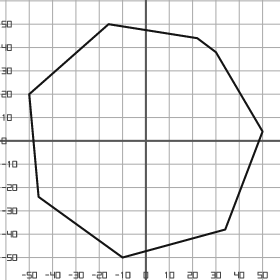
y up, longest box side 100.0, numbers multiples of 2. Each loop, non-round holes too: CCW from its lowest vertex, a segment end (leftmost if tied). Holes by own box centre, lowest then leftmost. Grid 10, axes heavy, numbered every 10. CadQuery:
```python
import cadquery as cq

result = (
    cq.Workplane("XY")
    .moveTo(-10.0, -50.0)
    .lineTo(34.0, -38.0)
    .lineTo(50.0, 4.0)
    .lineTo(30.0, 38.0)
    .lineTo(22.0, 44.0)
    .lineTo(-16.0, 50.0)
    .lineTo(-50.0, 20.0)
    .lineTo(-46.0, -24.0)
    .close()
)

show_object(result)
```